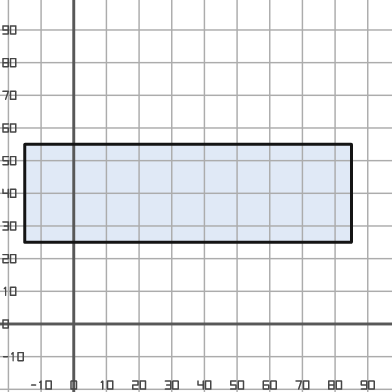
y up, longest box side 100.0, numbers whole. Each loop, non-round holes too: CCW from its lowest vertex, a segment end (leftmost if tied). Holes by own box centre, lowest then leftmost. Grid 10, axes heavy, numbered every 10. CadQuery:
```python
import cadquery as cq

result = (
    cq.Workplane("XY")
    .moveTo(-15.0, 25.0)
    .lineTo(85.0, 25.0)
    .lineTo(85.0, 55.0)
    .lineTo(-15.0, 55.0)
    .close()
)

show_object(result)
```